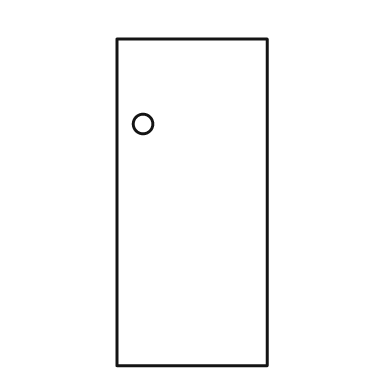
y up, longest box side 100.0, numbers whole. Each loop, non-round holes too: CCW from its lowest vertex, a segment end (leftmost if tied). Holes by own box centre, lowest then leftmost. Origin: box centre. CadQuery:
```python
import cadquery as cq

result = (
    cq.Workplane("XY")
    .moveTo(-23.0, -50.0)
    .lineTo(23.0, -50.0)
    .lineTo(23.0, 50.0)
    .lineTo(-23.0, 50.0)
    .close()
    .moveTo(-15.0, 24.0)
    .circle(3.0)
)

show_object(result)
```